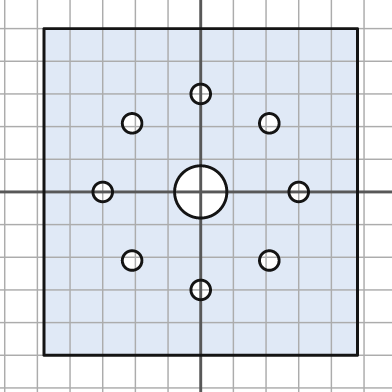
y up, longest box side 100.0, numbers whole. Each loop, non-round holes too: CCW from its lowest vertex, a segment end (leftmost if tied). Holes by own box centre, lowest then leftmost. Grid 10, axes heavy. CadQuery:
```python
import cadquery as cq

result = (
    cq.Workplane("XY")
    .moveTo(-48.0, -50.0)
    .lineTo(48.0, -50.0)
    .lineTo(48.0, 50.0)
    .lineTo(-48.0, 50.0)
    .close()
    .moveTo(0.0, -30.0)
    .circle(3.0)
    .moveTo(-21.0, -21.0)
    .circle(3.0)
    .moveTo(21.0, -21.0)
    .circle(3.0)
    .moveTo(-30.0, 0.0)
    .circle(3.0)
    .moveTo(0.0, 0.0)
    .circle(8.0)
    .moveTo(30.0, 0.0)
    .circle(3.0)
    .moveTo(-21.0, 21.0)
    .circle(3.0)
    .moveTo(21.0, 21.0)
    .circle(3.0)
    .moveTo(0.0, 30.0)
    .circle(3.0)
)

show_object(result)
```